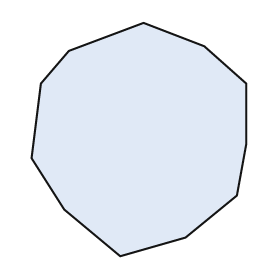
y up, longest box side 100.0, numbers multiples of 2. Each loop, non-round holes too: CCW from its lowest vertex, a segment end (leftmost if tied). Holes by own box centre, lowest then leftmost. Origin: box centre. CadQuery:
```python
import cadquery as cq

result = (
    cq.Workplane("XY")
    .moveTo(-8.0, -50.0)
    .lineTo(20.0, -42.0)
    .lineTo(42.0, -24.0)
    .lineTo(46.0, -2.0)
    .lineTo(46.0, 24.0)
    .lineTo(28.0, 40.0)
    .lineTo(2.0, 50.0)
    .lineTo(-30.0, 38.0)
    .lineTo(-42.0, 24.0)
    .lineTo(-46.0, -8.0)
    .lineTo(-32.0, -30.0)
    .close()
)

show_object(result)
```